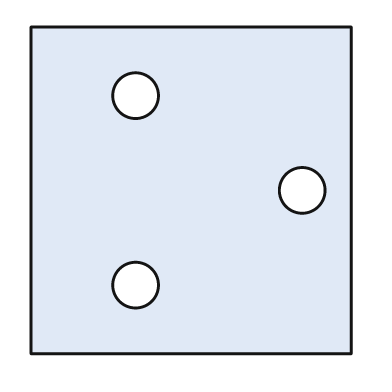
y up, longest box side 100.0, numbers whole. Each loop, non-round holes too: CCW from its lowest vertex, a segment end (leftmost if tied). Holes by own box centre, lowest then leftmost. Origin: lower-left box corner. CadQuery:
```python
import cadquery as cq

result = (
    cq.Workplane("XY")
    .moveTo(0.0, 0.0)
    .lineTo(98.0, 0.0)
    .lineTo(98.0, 100.0)
    .lineTo(0.0, 100.0)
    .close()
    .moveTo(32.0, 21.0)
    .circle(7.0)
    .moveTo(83.0, 50.0)
    .circle(7.0)
    .moveTo(32.0, 79.0)
    .circle(7.0)
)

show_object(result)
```